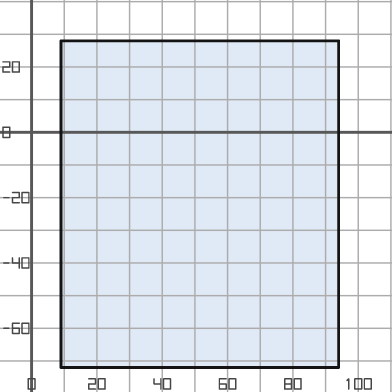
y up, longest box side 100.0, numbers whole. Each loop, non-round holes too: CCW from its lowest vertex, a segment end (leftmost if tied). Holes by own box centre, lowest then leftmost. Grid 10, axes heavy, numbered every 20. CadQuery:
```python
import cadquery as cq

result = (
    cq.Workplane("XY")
    .moveTo(9.0, -72.0)
    .lineTo(94.0, -72.0)
    .lineTo(94.0, 28.0)
    .lineTo(9.0, 28.0)
    .close()
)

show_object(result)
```